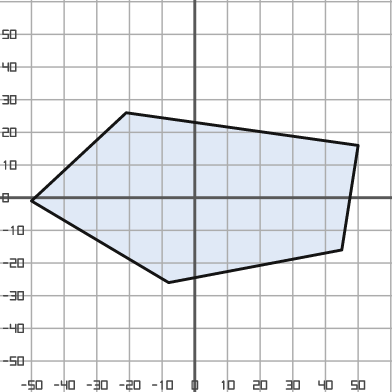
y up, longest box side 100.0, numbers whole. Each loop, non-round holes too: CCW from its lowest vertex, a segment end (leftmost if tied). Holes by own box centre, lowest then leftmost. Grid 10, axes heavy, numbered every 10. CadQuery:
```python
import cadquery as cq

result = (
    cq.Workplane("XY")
    .moveTo(-8.0, -26.0)
    .lineTo(45.0, -16.0)
    .lineTo(50.0, 16.0)
    .lineTo(-21.0, 26.0)
    .lineTo(-50.0, -1.0)
    .close()
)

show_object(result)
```